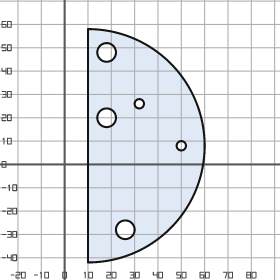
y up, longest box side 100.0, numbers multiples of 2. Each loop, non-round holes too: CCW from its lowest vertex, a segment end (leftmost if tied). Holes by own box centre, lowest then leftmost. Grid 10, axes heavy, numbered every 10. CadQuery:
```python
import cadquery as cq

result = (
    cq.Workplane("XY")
    .moveTo(10.0, -42.0)
    .threePointArc((60.0, 8.0), (10.0, 58.0))
    .close()
    .moveTo(26.0, -28.0)
    .circle(4.0)
    .moveTo(50.0, 8.0)
    .circle(2.0)
    .moveTo(18.0, 20.0)
    .circle(4.0)
    .moveTo(32.0, 26.0)
    .circle(2.0)
    .moveTo(18.0, 48.0)
    .circle(4.0)
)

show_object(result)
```